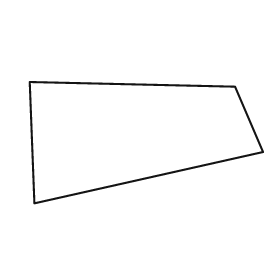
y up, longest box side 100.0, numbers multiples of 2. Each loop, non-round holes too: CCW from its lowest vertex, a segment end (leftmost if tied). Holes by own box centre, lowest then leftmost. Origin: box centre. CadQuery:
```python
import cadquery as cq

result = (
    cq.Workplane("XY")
    .moveTo(-48.0, -26.0)
    .lineTo(50.0, -4.0)
    .lineTo(38.0, 24.0)
    .lineTo(-50.0, 26.0)
    .close()
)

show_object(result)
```